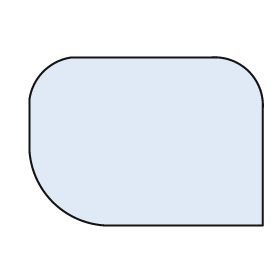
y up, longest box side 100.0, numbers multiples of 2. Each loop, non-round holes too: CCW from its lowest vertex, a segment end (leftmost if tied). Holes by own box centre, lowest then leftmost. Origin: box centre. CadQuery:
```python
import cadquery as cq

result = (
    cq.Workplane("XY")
    .moveTo(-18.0, -36.0)
    .lineTo(50.0, -36.0)
    .lineTo(50.0, 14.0)
    .threePointArc((44.0, 30.0), (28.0, 36.0))
    .lineTo(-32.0, 36.0)
    .threePointArc((-44.0, 30.0), (-50.0, 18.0))
    .lineTo(-50.0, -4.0)
    .threePointArc((-40.0, -26.0), (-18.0, -36.0))
    .close()
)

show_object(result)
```